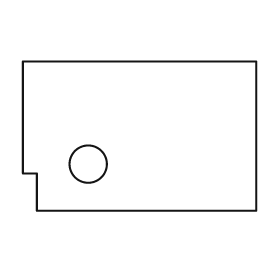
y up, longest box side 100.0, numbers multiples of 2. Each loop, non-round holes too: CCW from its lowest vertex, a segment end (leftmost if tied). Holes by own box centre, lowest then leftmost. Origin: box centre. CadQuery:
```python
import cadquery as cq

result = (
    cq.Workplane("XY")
    .moveTo(-44.0, -32.0)
    .lineTo(50.0, -32.0)
    .lineTo(50.0, 32.0)
    .lineTo(-50.0, 32.0)
    .lineTo(-50.0, -16.0)
    .lineTo(-44.0, -16.0)
    .close()
    .moveTo(-22.0, -12.0)
    .circle(8.0)
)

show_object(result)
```